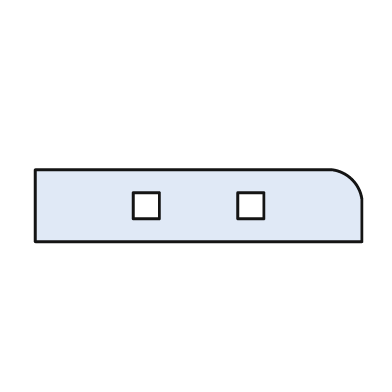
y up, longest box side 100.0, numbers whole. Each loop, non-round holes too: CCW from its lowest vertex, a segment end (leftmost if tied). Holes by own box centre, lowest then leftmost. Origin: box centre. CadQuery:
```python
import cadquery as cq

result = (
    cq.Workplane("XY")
    .moveTo(-50.0, -11.0)
    .lineTo(50.0, -11.0)
    .lineTo(50.0, 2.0)
    .threePointArc((47.0, 8.0), (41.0, 11.0))
    .lineTo(-50.0, 11.0)
    .close()
    .moveTo(-20.0, -4.0)
    .lineTo(-12.0, -4.0)
    .lineTo(-12.0, 4.0)
    .lineTo(-20.0, 4.0)
    .close()
    .moveTo(12.0, -4.0)
    .lineTo(20.0, -4.0)
    .lineTo(20.0, 4.0)
    .lineTo(12.0, 4.0)
    .close()
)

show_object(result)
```